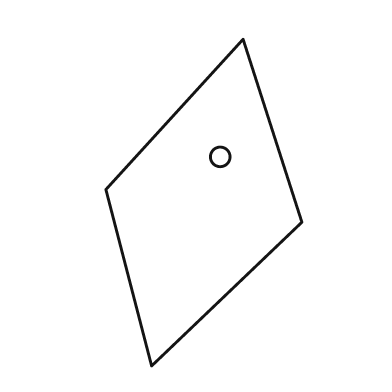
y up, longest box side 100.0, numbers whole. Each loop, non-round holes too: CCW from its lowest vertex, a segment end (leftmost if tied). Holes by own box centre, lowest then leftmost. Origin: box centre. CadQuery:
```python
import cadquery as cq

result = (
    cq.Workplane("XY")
    .moveTo(-16.0, -50.0)
    .lineTo(30.0, -6.0)
    .lineTo(12.0, 50.0)
    .lineTo(-30.0, 4.0)
    .close()
    .moveTo(5.0, 14.0)
    .circle(3.0)
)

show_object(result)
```